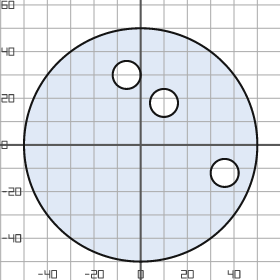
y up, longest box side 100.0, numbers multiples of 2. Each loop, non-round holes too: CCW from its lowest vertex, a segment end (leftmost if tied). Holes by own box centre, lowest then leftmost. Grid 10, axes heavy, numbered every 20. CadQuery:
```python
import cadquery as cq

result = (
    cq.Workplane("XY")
    .moveTo(0.0, 0.0)
    .circle(50.0)
    .moveTo(36.0, -12.0)
    .circle(6.0)
    .moveTo(10.0, 18.0)
    .circle(6.0)
    .moveTo(-6.0, 30.0)
    .circle(6.0)
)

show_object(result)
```